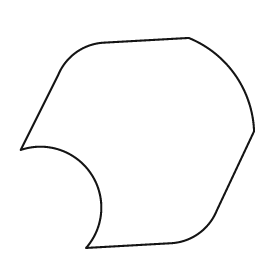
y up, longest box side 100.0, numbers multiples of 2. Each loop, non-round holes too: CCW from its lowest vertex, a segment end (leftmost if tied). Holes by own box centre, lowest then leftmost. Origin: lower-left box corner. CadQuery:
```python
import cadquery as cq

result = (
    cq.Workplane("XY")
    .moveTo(28.0, 0.0)
    .lineTo(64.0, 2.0)
    .threePointArc((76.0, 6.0), (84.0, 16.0))
    .lineTo(100.0, 50.0)
    .threePointArc((92.0, 74.0), (72.0, 90.0))
    .lineTo(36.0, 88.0)
    .threePointArc((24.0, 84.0), (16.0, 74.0))
    .lineTo(0.0, 42.0)
    .threePointArc((30.0, 32.0), (28.0, 0.0))
    .close()
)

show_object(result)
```